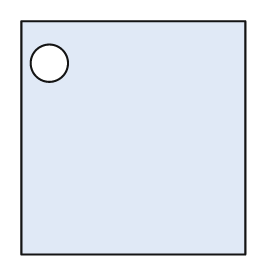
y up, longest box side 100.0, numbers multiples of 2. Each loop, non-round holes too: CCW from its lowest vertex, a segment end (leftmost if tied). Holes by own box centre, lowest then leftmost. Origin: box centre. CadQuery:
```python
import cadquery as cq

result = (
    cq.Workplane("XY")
    .moveTo(-48.0, -50.0)
    .lineTo(48.0, -50.0)
    .lineTo(48.0, 50.0)
    .lineTo(-48.0, 50.0)
    .close()
    .moveTo(-36.0, 32.0)
    .circle(8.0)
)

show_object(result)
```